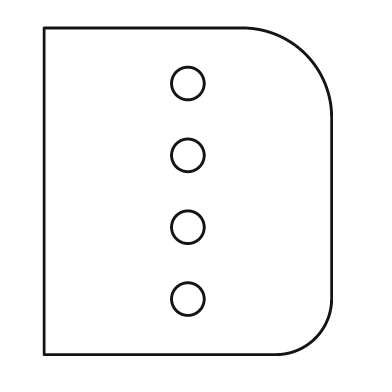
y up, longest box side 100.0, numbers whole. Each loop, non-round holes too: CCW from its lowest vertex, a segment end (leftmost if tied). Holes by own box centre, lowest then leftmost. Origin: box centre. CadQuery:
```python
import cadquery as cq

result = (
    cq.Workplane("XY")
    .moveTo(-44.0, -50.0)
    .lineTo(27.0, -50.0)
    .threePointArc((39.0, -45.0), (44.0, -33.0))
    .lineTo(44.0, 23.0)
    .threePointArc((36.0, 42.0), (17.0, 50.0))
    .lineTo(-44.0, 50.0)
    .close()
    .moveTo(0.0, -33.0)
    .circle(5.0)
    .moveTo(0.0, -11.0)
    .circle(5.0)
    .moveTo(0.0, 11.0)
    .circle(5.0)
    .moveTo(0.0, 33.0)
    .circle(5.0)
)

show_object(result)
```